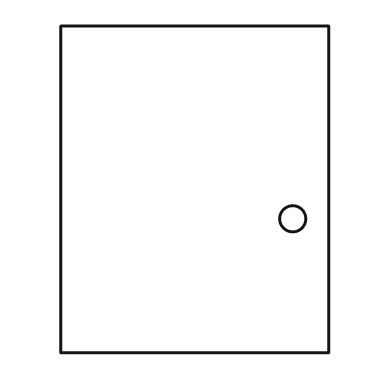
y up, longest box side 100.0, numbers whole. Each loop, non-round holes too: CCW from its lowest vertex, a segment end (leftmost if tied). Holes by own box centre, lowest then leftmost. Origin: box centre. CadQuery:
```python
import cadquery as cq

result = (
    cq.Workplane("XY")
    .moveTo(-41.0, -50.0)
    .lineTo(41.0, -50.0)
    .lineTo(41.0, 50.0)
    .lineTo(-41.0, 50.0)
    .close()
    .moveTo(30.0, -9.0)
    .circle(4.0)
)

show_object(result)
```